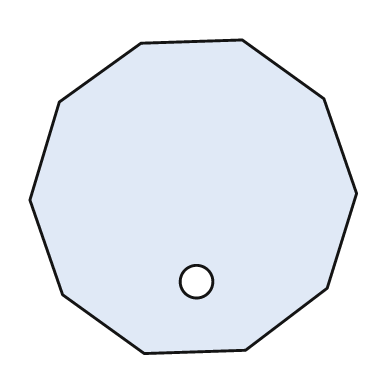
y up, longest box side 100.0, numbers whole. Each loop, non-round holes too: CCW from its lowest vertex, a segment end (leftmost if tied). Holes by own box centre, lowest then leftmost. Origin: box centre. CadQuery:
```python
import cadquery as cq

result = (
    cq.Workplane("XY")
    .moveTo(-15.0, -48.0)
    .lineTo(16.0, -47.0)
    .lineTo(41.0, -28.0)
    .lineTo(50.0, 1.0)
    .lineTo(40.0, 30.0)
    .lineTo(15.0, 48.0)
    .lineTo(-16.0, 47.0)
    .lineTo(-41.0, 29.0)
    .lineTo(-50.0, -1.0)
    .lineTo(-40.0, -30.0)
    .close()
    .moveTo(1.0, -26.0)
    .circle(5.0)
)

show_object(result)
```